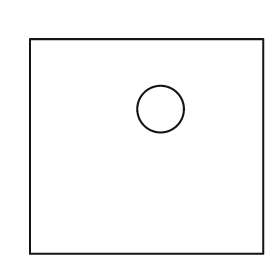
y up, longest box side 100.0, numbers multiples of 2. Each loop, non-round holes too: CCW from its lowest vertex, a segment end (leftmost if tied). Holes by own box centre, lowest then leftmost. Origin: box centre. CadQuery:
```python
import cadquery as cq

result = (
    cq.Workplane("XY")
    .moveTo(-50.0, -46.0)
    .lineTo(50.0, -46.0)
    .lineTo(50.0, 46.0)
    .lineTo(-50.0, 46.0)
    .close()
    .moveTo(6.0, 16.0)
    .circle(10.0)
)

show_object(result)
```